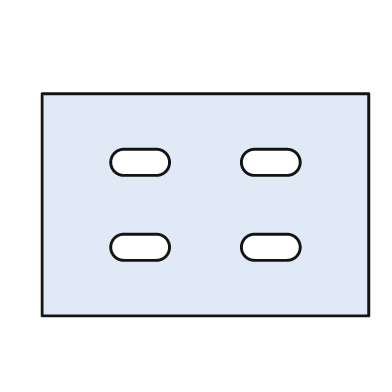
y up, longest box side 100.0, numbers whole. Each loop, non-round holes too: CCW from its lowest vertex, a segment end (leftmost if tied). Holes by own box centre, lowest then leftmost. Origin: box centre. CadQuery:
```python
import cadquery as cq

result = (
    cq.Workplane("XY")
    .moveTo(-50.0, -34.0)
    .lineTo(50.0, -34.0)
    .lineTo(50.0, 34.0)
    .lineTo(-50.0, 34.0)
    .close()
    .moveTo(-25.0, -17.0)
    .lineTo(-15.0, -17.0)
    .threePointArc((-11.0, -13.0), (-15.0, -9.0))
    .lineTo(-25.0, -9.0)
    .threePointArc((-29.0, -13.0), (-25.0, -17.0))
    .close()
    .moveTo(15.0, -17.0)
    .lineTo(25.0, -17.0)
    .threePointArc((29.0, -13.0), (25.0, -9.0))
    .lineTo(15.0, -9.0)
    .threePointArc((11.0, -13.0), (15.0, -17.0))
    .close()
    .moveTo(-25.0, 9.0)
    .lineTo(-15.0, 9.0)
    .threePointArc((-11.0, 13.0), (-15.0, 17.0))
    .lineTo(-25.0, 17.0)
    .threePointArc((-29.0, 13.0), (-25.0, 9.0))
    .close()
    .moveTo(15.0, 9.0)
    .lineTo(25.0, 9.0)
    .threePointArc((29.0, 13.0), (25.0, 17.0))
    .lineTo(15.0, 17.0)
    .threePointArc((11.0, 13.0), (15.0, 9.0))
    .close()
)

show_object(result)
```